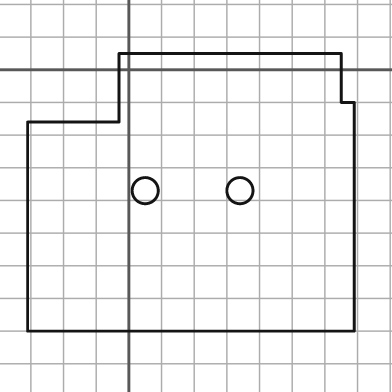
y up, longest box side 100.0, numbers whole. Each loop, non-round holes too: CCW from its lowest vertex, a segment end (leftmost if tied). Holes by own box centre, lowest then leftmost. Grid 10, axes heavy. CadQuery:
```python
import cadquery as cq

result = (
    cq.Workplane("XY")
    .moveTo(-31.0, -80.0)
    .lineTo(69.0, -80.0)
    .lineTo(69.0, -10.0)
    .lineTo(65.0, -10.0)
    .lineTo(65.0, 5.0)
    .lineTo(-3.0, 5.0)
    .lineTo(-3.0, -16.0)
    .lineTo(-31.0, -16.0)
    .close()
    .moveTo(5.0, -37.0)
    .circle(4.0)
    .moveTo(34.0, -37.0)
    .circle(4.0)
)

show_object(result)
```